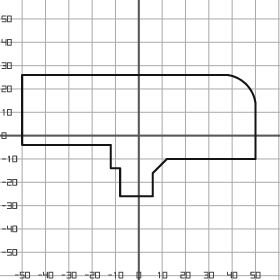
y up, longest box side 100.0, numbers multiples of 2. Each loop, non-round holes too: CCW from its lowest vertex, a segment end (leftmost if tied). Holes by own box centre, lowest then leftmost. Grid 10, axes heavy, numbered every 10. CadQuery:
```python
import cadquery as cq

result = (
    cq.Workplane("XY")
    .moveTo(-8.0, -26.0)
    .lineTo(6.0, -26.0)
    .lineTo(6.0, -16.0)
    .lineTo(12.0, -10.0)
    .lineTo(50.0, -10.0)
    .lineTo(50.0, 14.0)
    .threePointArc((46.0, 22.0), (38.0, 26.0))
    .lineTo(-50.0, 26.0)
    .lineTo(-50.0, -4.0)
    .lineTo(-12.0, -4.0)
    .lineTo(-12.0, -14.0)
    .lineTo(-8.0, -14.0)
    .close()
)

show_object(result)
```